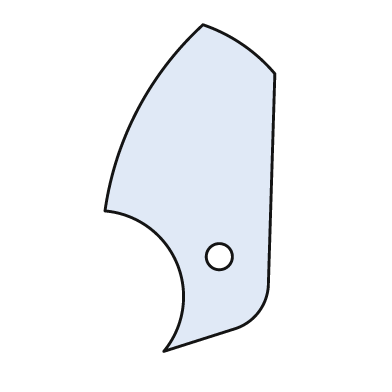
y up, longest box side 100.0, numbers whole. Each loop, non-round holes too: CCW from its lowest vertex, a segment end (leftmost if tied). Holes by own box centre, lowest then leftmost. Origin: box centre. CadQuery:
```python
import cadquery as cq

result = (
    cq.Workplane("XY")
    .moveTo(-8.0, -50.0)
    .lineTo(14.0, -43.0)
    .threePointArc((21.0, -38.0), (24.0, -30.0))
    .lineTo(26.0, 35.0)
    .threePointArc((16.0, 44.0), (4.0, 50.0))
    .threePointArc((-16.0, 24.0), (-26.0, -7.0))
    .threePointArc((-4.0, -23.0), (-8.0, -50.0))
    .close()
    .moveTo(9.0, -21.0)
    .circle(4.0)
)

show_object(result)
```